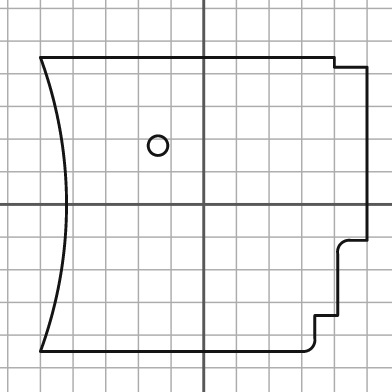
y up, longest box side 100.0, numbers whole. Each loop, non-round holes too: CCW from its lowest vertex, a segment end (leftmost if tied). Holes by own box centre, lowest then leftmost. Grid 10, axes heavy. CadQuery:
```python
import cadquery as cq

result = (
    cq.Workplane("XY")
    .moveTo(-50.0, -45.0)
    .lineTo(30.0, -45.0)
    .threePointArc((33.0, -44.0), (34.0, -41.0))
    .lineTo(34.0, -34.0)
    .lineTo(41.0, -34.0)
    .lineTo(41.0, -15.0)
    .threePointArc((42.0, -12.0), (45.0, -11.0))
    .lineTo(50.0, -11.0)
    .lineTo(50.0, 42.0)
    .lineTo(40.0, 42.0)
    .lineTo(40.0, 45.0)
    .lineTo(-50.0, 45.0)
    .threePointArc((-42.0, 0.0), (-50.0, -45.0))
    .close()
    .moveTo(-14.0, 18.0)
    .circle(3.0)
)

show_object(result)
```